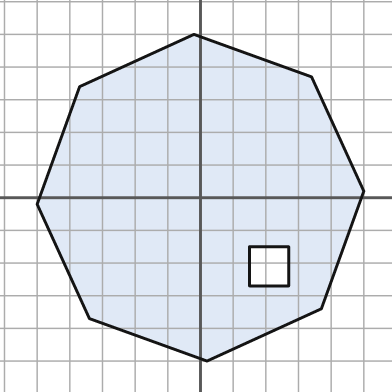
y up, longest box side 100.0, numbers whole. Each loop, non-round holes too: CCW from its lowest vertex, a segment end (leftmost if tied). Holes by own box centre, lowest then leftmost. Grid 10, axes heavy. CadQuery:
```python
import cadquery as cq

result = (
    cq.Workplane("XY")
    .moveTo(2.0, -50.0)
    .lineTo(37.0, -34.0)
    .lineTo(50.0, 2.0)
    .lineTo(34.0, 37.0)
    .lineTo(-2.0, 50.0)
    .lineTo(-37.0, 34.0)
    .lineTo(-50.0, -2.0)
    .lineTo(-34.0, -37.0)
    .close()
    .moveTo(15.0, -27.0)
    .lineTo(27.0, -27.0)
    .lineTo(27.0, -15.0)
    .lineTo(15.0, -15.0)
    .close()
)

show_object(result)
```